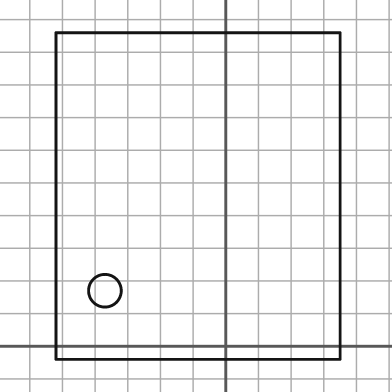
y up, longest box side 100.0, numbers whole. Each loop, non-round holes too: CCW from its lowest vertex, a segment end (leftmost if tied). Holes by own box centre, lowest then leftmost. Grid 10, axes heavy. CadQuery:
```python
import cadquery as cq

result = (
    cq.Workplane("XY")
    .moveTo(-52.0, -4.0)
    .lineTo(35.0, -4.0)
    .lineTo(35.0, 96.0)
    .lineTo(-52.0, 96.0)
    .close()
    .moveTo(-37.0, 17.0)
    .circle(5.0)
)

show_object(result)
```